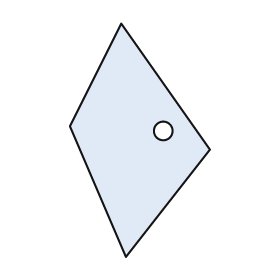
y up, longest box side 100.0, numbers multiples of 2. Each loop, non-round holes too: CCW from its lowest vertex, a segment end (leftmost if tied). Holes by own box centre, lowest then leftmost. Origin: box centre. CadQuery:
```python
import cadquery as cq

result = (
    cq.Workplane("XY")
    .moveTo(-6.0, -50.0)
    .lineTo(30.0, -4.0)
    .lineTo(-8.0, 50.0)
    .lineTo(-30.0, 6.0)
    .close()
    .moveTo(10.0, 4.0)
    .circle(4.0)
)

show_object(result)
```